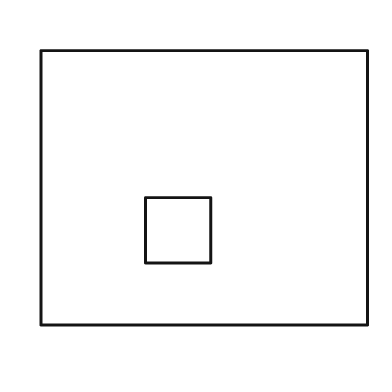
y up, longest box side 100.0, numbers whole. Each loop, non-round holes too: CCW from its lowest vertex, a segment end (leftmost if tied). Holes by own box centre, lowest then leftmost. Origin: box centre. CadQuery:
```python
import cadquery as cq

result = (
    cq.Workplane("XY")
    .moveTo(-50.0, -42.0)
    .lineTo(50.0, -42.0)
    .lineTo(50.0, 42.0)
    .lineTo(-50.0, 42.0)
    .close()
    .moveTo(-18.0, -23.0)
    .lineTo(2.0, -23.0)
    .lineTo(2.0, -3.0)
    .lineTo(-18.0, -3.0)
    .close()
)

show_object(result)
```